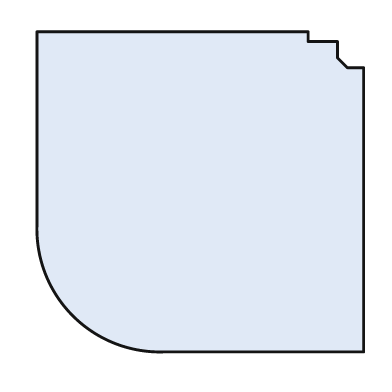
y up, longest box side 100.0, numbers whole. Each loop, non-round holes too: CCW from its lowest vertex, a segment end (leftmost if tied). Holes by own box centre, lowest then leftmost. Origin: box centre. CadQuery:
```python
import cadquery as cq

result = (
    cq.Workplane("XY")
    .moveTo(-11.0, -49.0)
    .lineTo(50.0, -49.0)
    .lineTo(50.0, 38.0)
    .lineTo(45.0, 38.0)
    .lineTo(42.0, 41.0)
    .lineTo(42.0, 46.0)
    .lineTo(33.0, 46.0)
    .lineTo(33.0, 49.0)
    .lineTo(-50.0, 49.0)
    .lineTo(-50.0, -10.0)
    .threePointArc((-39.0, -38.0), (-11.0, -49.0))
    .close()
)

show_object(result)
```